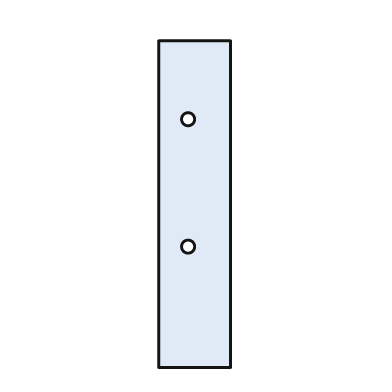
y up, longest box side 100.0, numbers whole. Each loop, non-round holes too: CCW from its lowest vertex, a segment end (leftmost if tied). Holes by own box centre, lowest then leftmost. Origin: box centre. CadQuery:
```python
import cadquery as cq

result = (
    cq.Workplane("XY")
    .moveTo(-11.0, -50.0)
    .lineTo(11.0, -50.0)
    .lineTo(11.0, 50.0)
    .lineTo(-11.0, 50.0)
    .close()
    .moveTo(-2.0, -13.0)
    .circle(2.0)
    .moveTo(-2.0, 26.0)
    .circle(2.0)
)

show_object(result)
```